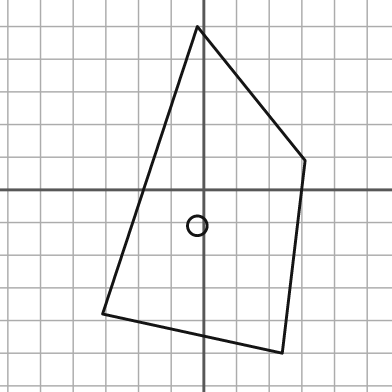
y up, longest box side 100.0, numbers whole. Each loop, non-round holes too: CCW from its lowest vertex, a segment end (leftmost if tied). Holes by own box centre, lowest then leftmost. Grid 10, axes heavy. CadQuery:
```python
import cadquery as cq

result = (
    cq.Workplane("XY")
    .moveTo(24.0, -50.0)
    .lineTo(31.0, 9.0)
    .lineTo(-2.0, 50.0)
    .lineTo(-31.0, -38.0)
    .close()
    .moveTo(-2.0, -11.0)
    .circle(3.0)
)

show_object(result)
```